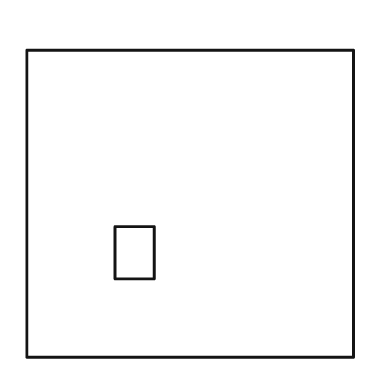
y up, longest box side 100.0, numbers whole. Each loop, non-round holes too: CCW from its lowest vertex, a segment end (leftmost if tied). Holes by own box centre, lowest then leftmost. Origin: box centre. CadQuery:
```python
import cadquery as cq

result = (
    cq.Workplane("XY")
    .moveTo(-50.0, -47.0)
    .lineTo(50.0, -47.0)
    .lineTo(50.0, 47.0)
    .lineTo(-50.0, 47.0)
    .close()
    .moveTo(-23.0, -23.0)
    .lineTo(-11.0, -23.0)
    .lineTo(-11.0, -7.0)
    .lineTo(-23.0, -7.0)
    .close()
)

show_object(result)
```